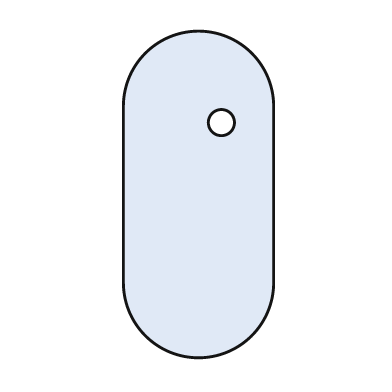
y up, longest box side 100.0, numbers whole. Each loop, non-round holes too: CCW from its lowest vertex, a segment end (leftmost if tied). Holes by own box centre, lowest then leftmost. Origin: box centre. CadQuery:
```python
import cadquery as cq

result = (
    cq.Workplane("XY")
    .moveTo(-23.0, -27.0)
    .threePointArc((0.0, -50.0), (23.0, -27.0))
    .lineTo(23.0, 27.0)
    .threePointArc((0.0, 50.0), (-23.0, 27.0))
    .close()
    .moveTo(7.0, 22.0)
    .circle(4.0)
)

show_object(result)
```